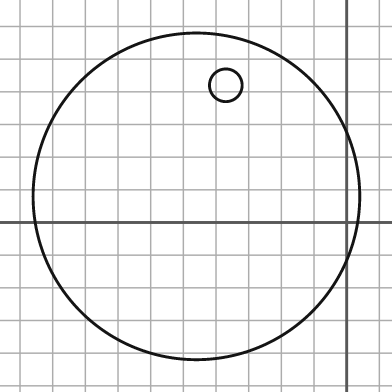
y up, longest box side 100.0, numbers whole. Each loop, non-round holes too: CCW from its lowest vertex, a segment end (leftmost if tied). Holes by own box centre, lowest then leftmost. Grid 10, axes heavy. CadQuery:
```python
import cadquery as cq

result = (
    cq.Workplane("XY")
    .moveTo(-46.0, 8.0)
    .circle(50.0)
    .moveTo(-37.0, 42.0)
    .circle(5.0)
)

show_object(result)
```